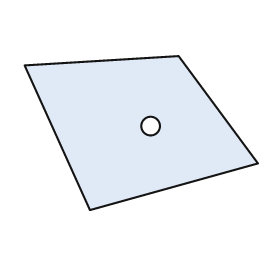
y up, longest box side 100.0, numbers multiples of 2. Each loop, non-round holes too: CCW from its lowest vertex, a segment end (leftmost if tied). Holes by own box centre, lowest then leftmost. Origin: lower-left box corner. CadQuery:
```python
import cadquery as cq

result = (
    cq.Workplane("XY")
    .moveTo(28.0, 0.0)
    .lineTo(100.0, 20.0)
    .lineTo(66.0, 66.0)
    .lineTo(0.0, 62.0)
    .close()
    .moveTo(54.0, 36.0)
    .circle(4.0)
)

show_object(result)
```